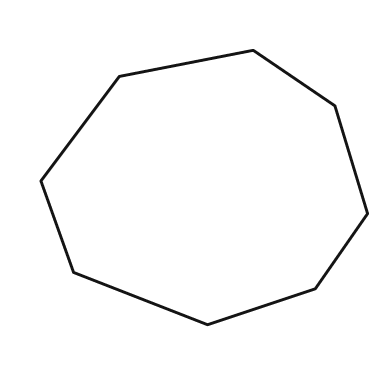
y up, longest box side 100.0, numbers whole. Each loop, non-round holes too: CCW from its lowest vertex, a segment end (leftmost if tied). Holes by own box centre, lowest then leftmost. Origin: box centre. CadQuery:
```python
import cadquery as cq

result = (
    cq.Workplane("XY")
    .moveTo(1.0, -42.0)
    .lineTo(34.0, -31.0)
    .lineTo(50.0, -8.0)
    .lineTo(40.0, 25.0)
    .lineTo(15.0, 42.0)
    .lineTo(-26.0, 34.0)
    .lineTo(-50.0, 2.0)
    .lineTo(-40.0, -26.0)
    .close()
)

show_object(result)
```